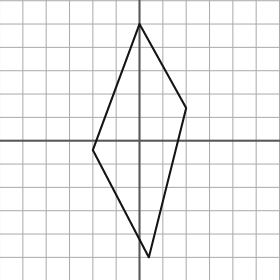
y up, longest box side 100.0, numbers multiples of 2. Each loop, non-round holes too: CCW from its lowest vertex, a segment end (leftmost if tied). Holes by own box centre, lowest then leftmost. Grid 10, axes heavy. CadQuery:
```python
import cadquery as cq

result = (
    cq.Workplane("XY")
    .moveTo(4.0, -50.0)
    .lineTo(20.0, 14.0)
    .lineTo(0.0, 50.0)
    .lineTo(-20.0, -4.0)
    .close()
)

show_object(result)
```